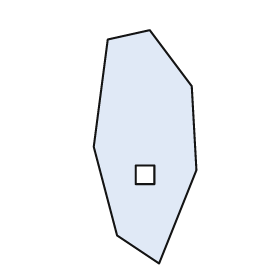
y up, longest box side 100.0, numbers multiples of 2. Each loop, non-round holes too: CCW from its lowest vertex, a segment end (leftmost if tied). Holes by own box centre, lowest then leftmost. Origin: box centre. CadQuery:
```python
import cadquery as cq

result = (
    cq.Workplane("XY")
    .moveTo(6.0, -50.0)
    .lineTo(22.0, -10.0)
    .lineTo(20.0, 26.0)
    .lineTo(2.0, 50.0)
    .lineTo(-16.0, 46.0)
    .lineTo(-22.0, 0.0)
    .lineTo(-12.0, -38.0)
    .close()
    .moveTo(-4.0, -16.0)
    .lineTo(4.0, -16.0)
    .lineTo(4.0, -8.0)
    .lineTo(-4.0, -8.0)
    .close()
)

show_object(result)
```